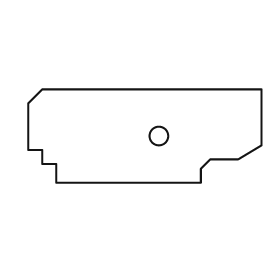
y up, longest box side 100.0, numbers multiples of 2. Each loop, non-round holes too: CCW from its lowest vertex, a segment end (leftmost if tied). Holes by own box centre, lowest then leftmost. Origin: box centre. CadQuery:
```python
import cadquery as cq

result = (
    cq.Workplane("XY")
    .moveTo(-38.0, -20.0)
    .lineTo(24.0, -20.0)
    .lineTo(24.0, -14.0)
    .lineTo(28.0, -10.0)
    .lineTo(40.0, -10.0)
    .lineTo(50.0, -4.0)
    .lineTo(50.0, 20.0)
    .lineTo(-44.0, 20.0)
    .lineTo(-50.0, 14.0)
    .lineTo(-50.0, -6.0)
    .lineTo(-44.0, -6.0)
    .lineTo(-44.0, -12.0)
    .lineTo(-38.0, -12.0)
    .close()
    .moveTo(6.0, 0.0)
    .circle(4.0)
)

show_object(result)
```